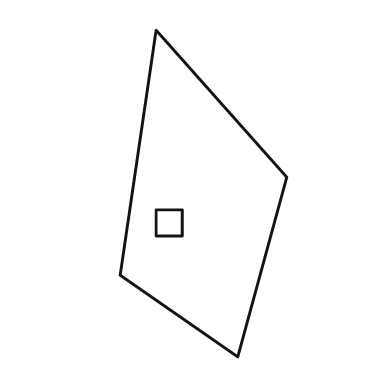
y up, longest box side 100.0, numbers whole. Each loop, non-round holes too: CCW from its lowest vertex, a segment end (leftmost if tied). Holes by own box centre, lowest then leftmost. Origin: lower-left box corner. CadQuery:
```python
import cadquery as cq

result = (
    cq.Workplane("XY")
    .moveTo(36.0, 0.0)
    .lineTo(51.0, 55.0)
    .lineTo(11.0, 100.0)
    .lineTo(0.0, 25.0)
    .close()
    .moveTo(11.0, 37.0)
    .lineTo(19.0, 37.0)
    .lineTo(19.0, 45.0)
    .lineTo(11.0, 45.0)
    .close()
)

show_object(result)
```